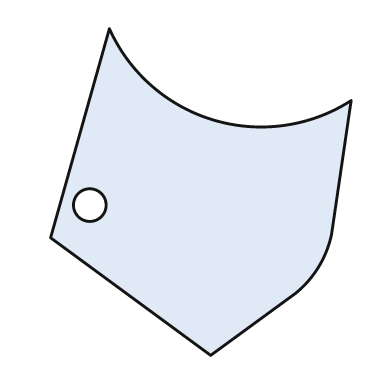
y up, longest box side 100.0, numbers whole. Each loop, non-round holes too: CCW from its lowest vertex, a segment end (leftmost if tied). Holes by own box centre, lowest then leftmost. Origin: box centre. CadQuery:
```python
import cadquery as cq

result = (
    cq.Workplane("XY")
    .moveTo(3.0, -50.0)
    .lineTo(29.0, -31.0)
    .threePointArc((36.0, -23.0), (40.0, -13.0))
    .lineTo(46.0, 28.0)
    .threePointArc((4.0, 22.0), (-28.0, 50.0))
    .lineTo(-46.0, -14.0)
    .close()
    .moveTo(-34.0, -4.0)
    .circle(5.0)
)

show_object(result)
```